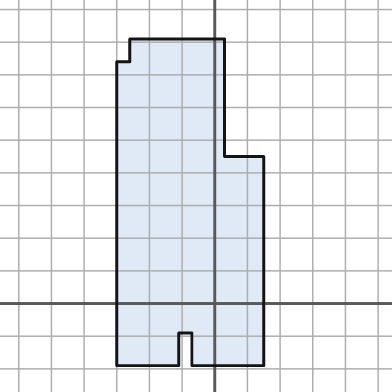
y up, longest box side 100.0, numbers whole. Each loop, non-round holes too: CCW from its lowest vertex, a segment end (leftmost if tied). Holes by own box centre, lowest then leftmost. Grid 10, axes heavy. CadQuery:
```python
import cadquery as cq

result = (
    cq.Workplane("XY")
    .moveTo(-30.0, -19.0)
    .lineTo(-11.0, -19.0)
    .lineTo(-11.0, -9.0)
    .lineTo(-7.0, -9.0)
    .lineTo(-7.0, -19.0)
    .lineTo(15.0, -19.0)
    .lineTo(15.0, 45.0)
    .lineTo(3.0, 45.0)
    .lineTo(3.0, 81.0)
    .lineTo(-26.0, 81.0)
    .lineTo(-26.0, 74.0)
    .lineTo(-30.0, 74.0)
    .close()
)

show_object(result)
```